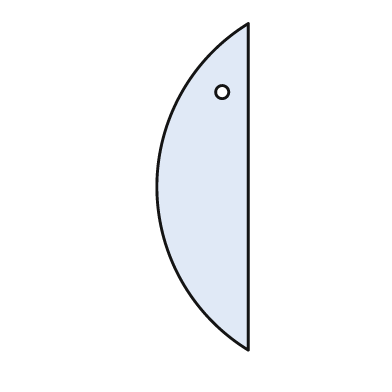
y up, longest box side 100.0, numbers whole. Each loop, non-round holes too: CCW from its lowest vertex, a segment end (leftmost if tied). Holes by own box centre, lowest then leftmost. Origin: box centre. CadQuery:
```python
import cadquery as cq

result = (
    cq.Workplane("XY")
    .moveTo(14.0, -50.0)
    .lineTo(14.0, 50.0)
    .threePointArc((-14.0, 0.0), (14.0, -50.0))
    .close()
    .moveTo(6.0, 29.0)
    .circle(2.0)
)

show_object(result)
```